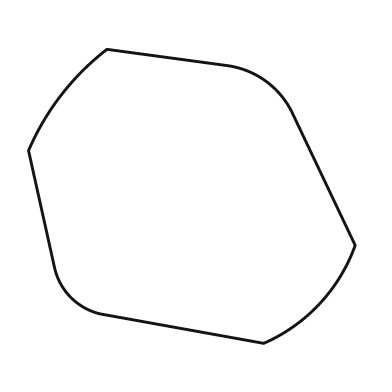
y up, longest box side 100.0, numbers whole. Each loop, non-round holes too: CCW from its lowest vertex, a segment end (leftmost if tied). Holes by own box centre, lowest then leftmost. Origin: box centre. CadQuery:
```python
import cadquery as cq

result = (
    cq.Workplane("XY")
    .moveTo(22.0, -45.0)
    .threePointArc((39.0, -33.0), (50.0, -15.0))
    .lineTo(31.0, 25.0)
    .threePointArc((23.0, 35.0), (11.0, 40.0))
    .lineTo(-26.0, 45.0)
    .threePointArc((-40.0, 31.0), (-50.0, 14.0))
    .lineTo(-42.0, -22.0)
    .threePointArc((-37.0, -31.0), (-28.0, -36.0))
    .close()
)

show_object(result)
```